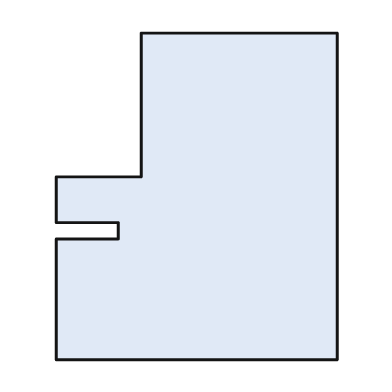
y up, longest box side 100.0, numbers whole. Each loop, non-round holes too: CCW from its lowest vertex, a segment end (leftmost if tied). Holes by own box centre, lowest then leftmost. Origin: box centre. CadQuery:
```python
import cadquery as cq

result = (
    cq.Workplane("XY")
    .moveTo(-43.0, -50.0)
    .lineTo(43.0, -50.0)
    .lineTo(43.0, 50.0)
    .lineTo(-17.0, 50.0)
    .lineTo(-17.0, 6.0)
    .lineTo(-43.0, 6.0)
    .lineTo(-43.0, -8.0)
    .lineTo(-24.0, -8.0)
    .lineTo(-24.0, -13.0)
    .lineTo(-43.0, -13.0)
    .close()
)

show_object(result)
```